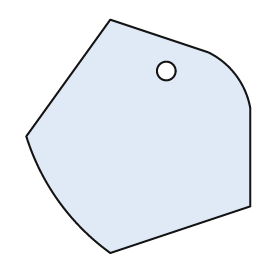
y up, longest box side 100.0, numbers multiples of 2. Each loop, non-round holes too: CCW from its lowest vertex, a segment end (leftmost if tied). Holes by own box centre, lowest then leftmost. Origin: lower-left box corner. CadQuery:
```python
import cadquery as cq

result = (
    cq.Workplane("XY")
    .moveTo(36.0, 0.0)
    .lineTo(96.0, 20.0)
    .lineTo(96.0, 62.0)
    .threePointArc((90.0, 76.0), (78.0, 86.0))
    .lineTo(36.0, 100.0)
    .lineTo(0.0, 50.0)
    .threePointArc((14.0, 22.0), (36.0, 0.0))
    .close()
    .moveTo(60.0, 78.0)
    .circle(4.0)
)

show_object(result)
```